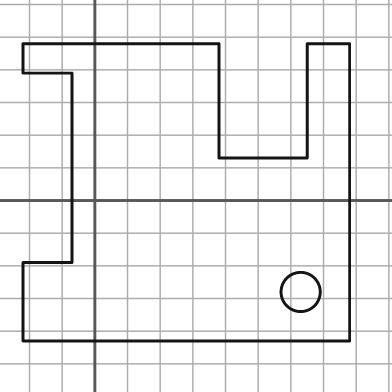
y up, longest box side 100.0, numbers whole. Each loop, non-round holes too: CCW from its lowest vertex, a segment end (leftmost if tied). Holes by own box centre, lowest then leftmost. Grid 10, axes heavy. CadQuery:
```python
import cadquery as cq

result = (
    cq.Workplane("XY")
    .moveTo(-22.0, -43.0)
    .lineTo(78.0, -43.0)
    .lineTo(78.0, 48.0)
    .lineTo(65.0, 48.0)
    .lineTo(65.0, 13.0)
    .lineTo(38.0, 13.0)
    .lineTo(38.0, 48.0)
    .lineTo(-22.0, 48.0)
    .lineTo(-22.0, 39.0)
    .lineTo(-7.0, 39.0)
    .lineTo(-7.0, -19.0)
    .lineTo(-22.0, -19.0)
    .close()
    .moveTo(63.0, -28.0)
    .circle(6.0)
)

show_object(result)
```